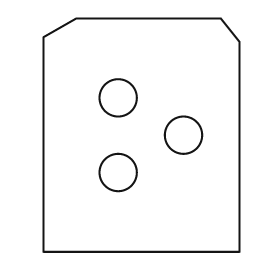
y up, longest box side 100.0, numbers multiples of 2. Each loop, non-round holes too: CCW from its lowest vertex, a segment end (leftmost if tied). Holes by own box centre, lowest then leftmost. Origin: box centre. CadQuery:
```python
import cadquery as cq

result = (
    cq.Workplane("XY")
    .moveTo(-42.0, -50.0)
    .lineTo(42.0, -50.0)
    .lineTo(42.0, 40.0)
    .lineTo(34.0, 50.0)
    .lineTo(-28.0, 50.0)
    .lineTo(-42.0, 42.0)
    .close()
    .moveTo(-10.0, -16.0)
    .circle(8.0)
    .moveTo(18.0, 0.0)
    .circle(8.0)
    .moveTo(-10.0, 16.0)
    .circle(8.0)
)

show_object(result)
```